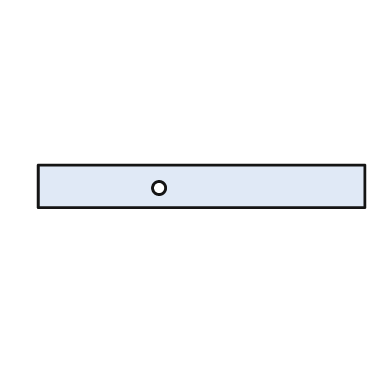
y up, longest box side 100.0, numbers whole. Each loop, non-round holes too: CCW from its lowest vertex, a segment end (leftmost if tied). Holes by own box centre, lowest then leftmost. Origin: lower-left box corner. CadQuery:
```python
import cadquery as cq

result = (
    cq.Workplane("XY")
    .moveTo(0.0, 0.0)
    .lineTo(100.0, 0.0)
    .lineTo(100.0, 13.0)
    .lineTo(0.0, 13.0)
    .close()
    .moveTo(37.0, 6.0)
    .circle(2.0)
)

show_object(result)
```